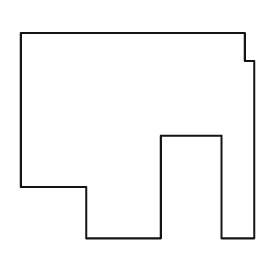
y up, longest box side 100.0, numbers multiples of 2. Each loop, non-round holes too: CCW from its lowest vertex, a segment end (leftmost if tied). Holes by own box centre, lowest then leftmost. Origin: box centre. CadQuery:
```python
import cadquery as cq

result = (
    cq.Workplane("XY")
    .moveTo(-22.0, -44.0)
    .lineTo(10.0, -44.0)
    .lineTo(10.0, 0.0)
    .lineTo(36.0, 0.0)
    .lineTo(36.0, -44.0)
    .lineTo(50.0, -44.0)
    .lineTo(50.0, 32.0)
    .lineTo(46.0, 32.0)
    .lineTo(46.0, 44.0)
    .lineTo(-50.0, 44.0)
    .lineTo(-50.0, -22.0)
    .lineTo(-22.0, -22.0)
    .close()
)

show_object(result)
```